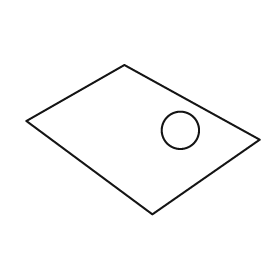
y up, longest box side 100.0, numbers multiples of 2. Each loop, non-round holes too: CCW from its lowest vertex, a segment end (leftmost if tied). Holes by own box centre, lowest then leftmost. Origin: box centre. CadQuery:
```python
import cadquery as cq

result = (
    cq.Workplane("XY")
    .moveTo(4.0, -32.0)
    .lineTo(50.0, 0.0)
    .lineTo(-8.0, 32.0)
    .lineTo(-50.0, 8.0)
    .close()
    .moveTo(16.0, 4.0)
    .circle(8.0)
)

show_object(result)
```